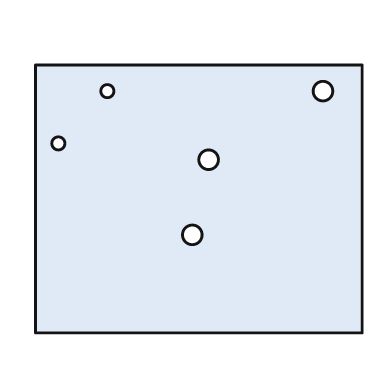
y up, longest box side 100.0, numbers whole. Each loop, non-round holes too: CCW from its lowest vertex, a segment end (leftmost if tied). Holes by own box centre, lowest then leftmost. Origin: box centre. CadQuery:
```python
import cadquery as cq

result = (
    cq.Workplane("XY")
    .moveTo(-50.0, -41.0)
    .lineTo(50.0, -41.0)
    .lineTo(50.0, 41.0)
    .lineTo(-50.0, 41.0)
    .close()
    .moveTo(-2.0, -11.0)
    .circle(3.0)
    .moveTo(3.0, 12.0)
    .circle(3.0)
    .moveTo(-43.0, 17.0)
    .circle(2.0)
    .moveTo(-28.0, 33.0)
    .circle(2.0)
    .moveTo(38.0, 33.0)
    .circle(3.0)
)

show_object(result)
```